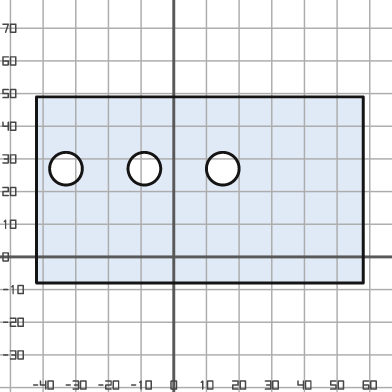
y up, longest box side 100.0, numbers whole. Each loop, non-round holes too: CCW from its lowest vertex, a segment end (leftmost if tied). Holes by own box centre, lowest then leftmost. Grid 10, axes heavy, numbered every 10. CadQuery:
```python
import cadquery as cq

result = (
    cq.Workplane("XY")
    .moveTo(-42.0, -8.0)
    .lineTo(58.0, -8.0)
    .lineTo(58.0, 49.0)
    .lineTo(-42.0, 49.0)
    .close()
    .moveTo(-33.0, 27.0)
    .circle(5.0)
    .moveTo(-9.0, 27.0)
    .circle(5.0)
    .moveTo(15.0, 27.0)
    .circle(5.0)
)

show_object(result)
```